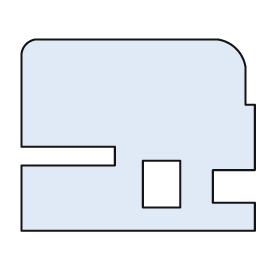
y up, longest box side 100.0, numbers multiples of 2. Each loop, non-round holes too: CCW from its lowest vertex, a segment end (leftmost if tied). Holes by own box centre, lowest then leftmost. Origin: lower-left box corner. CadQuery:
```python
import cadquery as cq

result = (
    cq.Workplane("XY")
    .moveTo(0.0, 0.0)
    .lineTo(100.0, 0.0)
    .lineTo(100.0, 12.0)
    .lineTo(82.0, 12.0)
    .lineTo(82.0, 26.0)
    .lineTo(100.0, 26.0)
    .lineTo(100.0, 54.0)
    .lineTo(96.0, 54.0)
    .lineTo(96.0, 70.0)
    .threePointArc((92.0, 78.0), (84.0, 82.0))
    .lineTo(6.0, 82.0)
    .threePointArc((2.0, 80.0), (0.0, 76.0))
    .lineTo(0.0, 36.0)
    .lineTo(40.0, 36.0)
    .lineTo(40.0, 28.0)
    .lineTo(0.0, 28.0)
    .close()
    .moveTo(52.0, 10.0)
    .lineTo(68.0, 10.0)
    .lineTo(68.0, 30.0)
    .lineTo(52.0, 30.0)
    .close()
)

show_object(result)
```